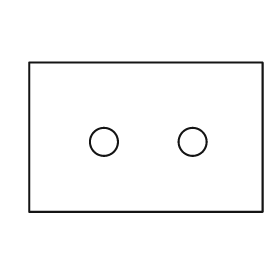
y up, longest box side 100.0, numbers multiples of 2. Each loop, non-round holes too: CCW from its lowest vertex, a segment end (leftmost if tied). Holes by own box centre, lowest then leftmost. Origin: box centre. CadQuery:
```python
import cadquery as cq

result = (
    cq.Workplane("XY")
    .moveTo(-50.0, -32.0)
    .lineTo(50.0, -32.0)
    .lineTo(50.0, 32.0)
    .lineTo(-50.0, 32.0)
    .close()
    .moveTo(-18.0, -2.0)
    .circle(6.0)
    .moveTo(20.0, -2.0)
    .circle(6.0)
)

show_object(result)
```